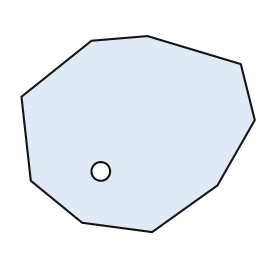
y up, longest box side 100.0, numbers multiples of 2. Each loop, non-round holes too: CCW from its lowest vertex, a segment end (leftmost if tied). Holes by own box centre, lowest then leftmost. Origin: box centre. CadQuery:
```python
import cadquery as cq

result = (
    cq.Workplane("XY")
    .moveTo(6.0, -42.0)
    .lineTo(34.0, -22.0)
    .lineTo(50.0, 6.0)
    .lineTo(44.0, 30.0)
    .lineTo(4.0, 42.0)
    .lineTo(-20.0, 40.0)
    .lineTo(-50.0, 16.0)
    .lineTo(-46.0, -20.0)
    .lineTo(-24.0, -38.0)
    .close()
    .moveTo(-16.0, -16.0)
    .circle(4.0)
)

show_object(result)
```